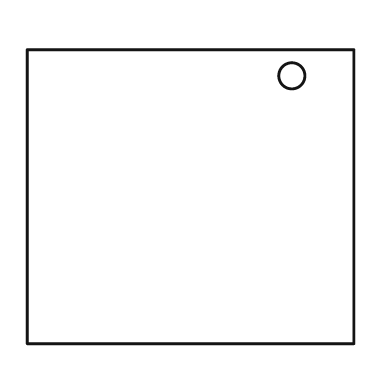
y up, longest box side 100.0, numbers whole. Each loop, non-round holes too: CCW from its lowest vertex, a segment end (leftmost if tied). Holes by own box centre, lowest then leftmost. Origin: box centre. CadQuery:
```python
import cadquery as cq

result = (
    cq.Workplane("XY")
    .moveTo(-50.0, -45.0)
    .lineTo(50.0, -45.0)
    .lineTo(50.0, 45.0)
    .lineTo(-50.0, 45.0)
    .close()
    .moveTo(31.0, 37.0)
    .circle(4.0)
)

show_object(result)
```